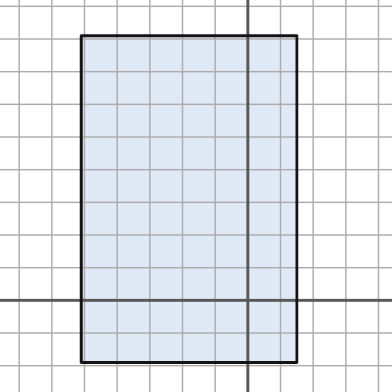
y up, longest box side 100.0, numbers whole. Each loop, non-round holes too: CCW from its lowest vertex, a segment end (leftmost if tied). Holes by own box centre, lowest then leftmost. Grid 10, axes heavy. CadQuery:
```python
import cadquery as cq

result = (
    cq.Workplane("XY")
    .moveTo(-51.0, -19.0)
    .lineTo(15.0, -19.0)
    .lineTo(15.0, 81.0)
    .lineTo(-51.0, 81.0)
    .close()
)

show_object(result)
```